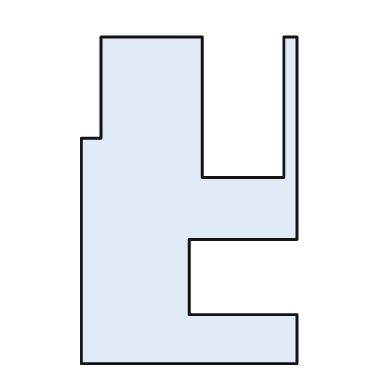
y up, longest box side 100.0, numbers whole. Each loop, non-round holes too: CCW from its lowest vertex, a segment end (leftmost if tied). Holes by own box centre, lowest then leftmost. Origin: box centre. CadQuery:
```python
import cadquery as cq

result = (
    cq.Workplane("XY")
    .moveTo(-33.0, -50.0)
    .lineTo(33.0, -50.0)
    .lineTo(33.0, -35.0)
    .lineTo(0.0, -35.0)
    .lineTo(0.0, -12.0)
    .lineTo(33.0, -12.0)
    .lineTo(33.0, 50.0)
    .lineTo(29.0, 50.0)
    .lineTo(29.0, 7.0)
    .lineTo(4.0, 7.0)
    .lineTo(4.0, 50.0)
    .lineTo(-27.0, 50.0)
    .lineTo(-27.0, 19.0)
    .lineTo(-33.0, 19.0)
    .close()
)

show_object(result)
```